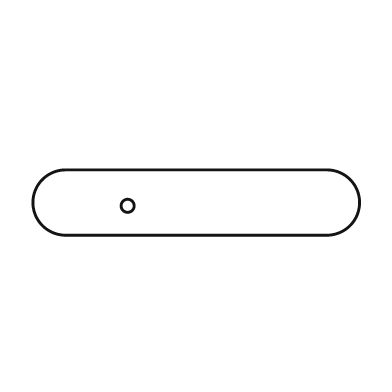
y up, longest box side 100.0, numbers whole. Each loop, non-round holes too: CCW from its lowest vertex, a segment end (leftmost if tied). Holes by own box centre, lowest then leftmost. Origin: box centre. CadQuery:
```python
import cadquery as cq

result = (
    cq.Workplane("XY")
    .moveTo(-40.0, -10.0)
    .lineTo(40.0, -10.0)
    .threePointArc((50.0, 0.0), (40.0, 10.0))
    .lineTo(-40.0, 10.0)
    .threePointArc((-50.0, 0.0), (-40.0, -10.0))
    .close()
    .moveTo(-21.0, -1.0)
    .circle(2.0)
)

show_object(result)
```